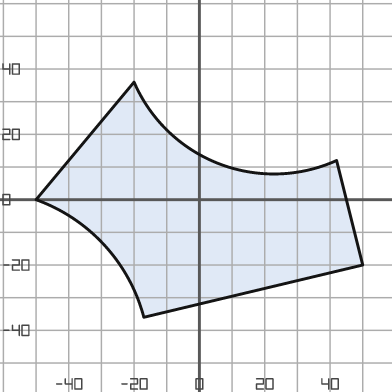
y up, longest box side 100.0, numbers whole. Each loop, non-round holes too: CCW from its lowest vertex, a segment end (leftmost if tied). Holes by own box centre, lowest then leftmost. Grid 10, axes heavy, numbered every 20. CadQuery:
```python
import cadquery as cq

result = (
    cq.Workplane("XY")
    .moveTo(-17.0, -36.0)
    .lineTo(50.0, -20.0)
    .lineTo(42.0, 12.0)
    .threePointArc((6.0, 11.0), (-20.0, 36.0))
    .lineTo(-50.0, 0.0)
    .threePointArc((-29.0, -14.0), (-17.0, -36.0))
    .close()
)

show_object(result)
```